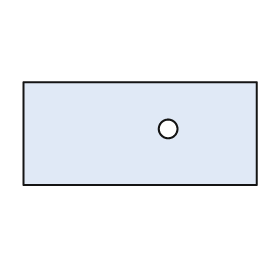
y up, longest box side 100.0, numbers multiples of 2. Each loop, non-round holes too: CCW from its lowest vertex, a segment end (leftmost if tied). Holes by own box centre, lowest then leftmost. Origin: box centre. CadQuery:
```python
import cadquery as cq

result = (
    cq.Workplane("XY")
    .moveTo(-50.0, -22.0)
    .lineTo(50.0, -22.0)
    .lineTo(50.0, 22.0)
    .lineTo(-50.0, 22.0)
    .close()
    .moveTo(12.0, 2.0)
    .circle(4.0)
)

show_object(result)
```